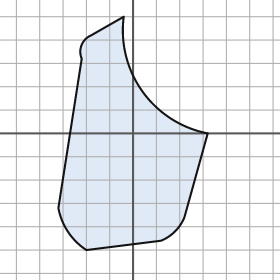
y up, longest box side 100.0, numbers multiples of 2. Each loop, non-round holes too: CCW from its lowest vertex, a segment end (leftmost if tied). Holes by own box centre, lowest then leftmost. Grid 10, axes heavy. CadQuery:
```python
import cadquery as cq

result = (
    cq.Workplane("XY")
    .moveTo(-20.0, -50.0)
    .lineTo(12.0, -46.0)
    .threePointArc((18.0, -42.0), (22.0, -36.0))
    .lineTo(32.0, 0.0)
    .threePointArc((4.0, 18.0), (-4.0, 50.0))
    .lineTo(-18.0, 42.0)
    .threePointArc((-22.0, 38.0), (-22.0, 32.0))
    .lineTo(-32.0, -32.0)
    .threePointArc((-28.0, -42.0), (-20.0, -50.0))
    .close()
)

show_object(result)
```